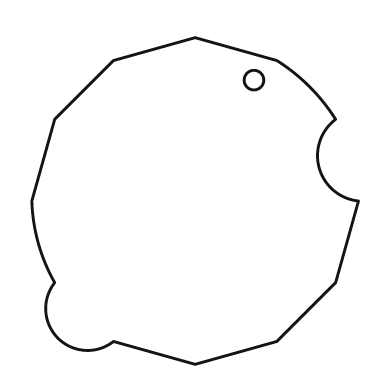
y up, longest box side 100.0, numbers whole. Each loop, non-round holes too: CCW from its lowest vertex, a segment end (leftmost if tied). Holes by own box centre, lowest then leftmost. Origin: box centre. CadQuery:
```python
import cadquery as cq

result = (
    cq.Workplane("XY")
    .moveTo(0.0, -50.0)
    .lineTo(25.0, -43.0)
    .lineTo(43.0, -25.0)
    .lineTo(50.0, 0.0)
    .threePointArc((38.0, 10.0), (43.0, 25.0))
    .threePointArc((35.0, 35.0), (25.0, 43.0))
    .lineTo(0.0, 50.0)
    .lineTo(-25.0, 43.0)
    .lineTo(-43.0, 25.0)
    .lineTo(-50.0, 0.0)
    .threePointArc((-48.0, -13.0), (-43.0, -25.0))
    .threePointArc((-42.0, -42.0), (-25.0, -43.0))
    .close()
    .moveTo(18.0, 37.0)
    .circle(3.0)
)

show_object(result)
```